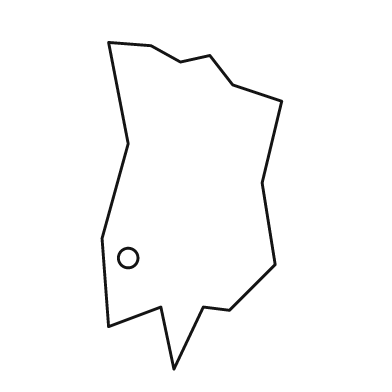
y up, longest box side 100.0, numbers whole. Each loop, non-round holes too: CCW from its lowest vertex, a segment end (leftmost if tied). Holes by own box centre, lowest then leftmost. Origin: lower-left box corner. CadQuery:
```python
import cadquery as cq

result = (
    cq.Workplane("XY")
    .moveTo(22.0, 0.0)
    .lineTo(31.0, 19.0)
    .lineTo(39.0, 18.0)
    .lineTo(53.0, 32.0)
    .lineTo(49.0, 57.0)
    .lineTo(55.0, 82.0)
    .lineTo(40.0, 87.0)
    .lineTo(33.0, 96.0)
    .lineTo(24.0, 94.0)
    .lineTo(15.0, 99.0)
    .lineTo(2.0, 100.0)
    .lineTo(8.0, 69.0)
    .lineTo(0.0, 40.0)
    .lineTo(2.0, 13.0)
    .lineTo(18.0, 19.0)
    .close()
    .moveTo(8.0, 34.0)
    .circle(3.0)
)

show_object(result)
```